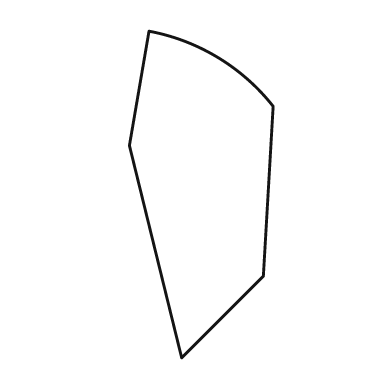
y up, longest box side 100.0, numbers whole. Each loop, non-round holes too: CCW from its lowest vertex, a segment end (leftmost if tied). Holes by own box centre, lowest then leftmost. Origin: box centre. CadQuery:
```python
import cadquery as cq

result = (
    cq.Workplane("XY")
    .moveTo(-6.0, -50.0)
    .lineTo(19.0, -25.0)
    .lineTo(22.0, 27.0)
    .threePointArc((5.0, 42.0), (-16.0, 50.0))
    .lineTo(-22.0, 15.0)
    .close()
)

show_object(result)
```